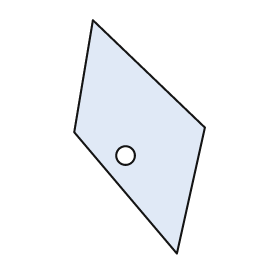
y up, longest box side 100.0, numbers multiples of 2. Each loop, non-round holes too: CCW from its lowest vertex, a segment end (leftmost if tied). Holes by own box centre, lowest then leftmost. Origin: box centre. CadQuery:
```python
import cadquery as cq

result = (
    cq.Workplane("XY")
    .moveTo(16.0, -50.0)
    .lineTo(28.0, 4.0)
    .lineTo(-20.0, 50.0)
    .lineTo(-28.0, 2.0)
    .close()
    .moveTo(-6.0, -8.0)
    .circle(4.0)
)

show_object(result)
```